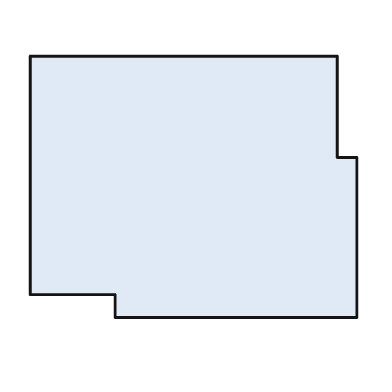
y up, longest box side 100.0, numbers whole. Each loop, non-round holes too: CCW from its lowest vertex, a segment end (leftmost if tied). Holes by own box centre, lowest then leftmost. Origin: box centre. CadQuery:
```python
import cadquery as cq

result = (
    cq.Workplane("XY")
    .moveTo(-24.0, -40.0)
    .lineTo(50.0, -40.0)
    .lineTo(50.0, 9.0)
    .lineTo(44.0, 9.0)
    .lineTo(44.0, 40.0)
    .lineTo(-50.0, 40.0)
    .lineTo(-50.0, -33.0)
    .lineTo(-24.0, -33.0)
    .close()
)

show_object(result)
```